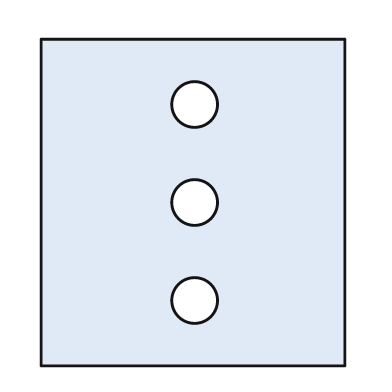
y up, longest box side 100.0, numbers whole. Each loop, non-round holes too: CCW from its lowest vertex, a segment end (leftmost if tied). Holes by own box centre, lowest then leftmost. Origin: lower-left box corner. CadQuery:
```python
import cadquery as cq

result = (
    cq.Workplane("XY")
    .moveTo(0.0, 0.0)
    .lineTo(93.0, 0.0)
    .lineTo(93.0, 100.0)
    .lineTo(0.0, 100.0)
    .close()
    .moveTo(47.0, 20.0)
    .circle(7.0)
    .moveTo(47.0, 50.0)
    .circle(7.0)
    .moveTo(47.0, 80.0)
    .circle(7.0)
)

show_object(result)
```